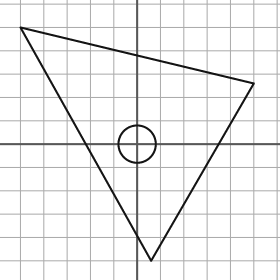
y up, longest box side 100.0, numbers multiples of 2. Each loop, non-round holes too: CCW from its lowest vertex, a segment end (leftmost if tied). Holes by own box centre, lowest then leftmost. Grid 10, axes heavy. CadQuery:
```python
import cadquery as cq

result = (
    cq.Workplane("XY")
    .moveTo(6.0, -50.0)
    .lineTo(50.0, 26.0)
    .lineTo(-50.0, 50.0)
    .close()
    .moveTo(0.0, 0.0)
    .circle(8.0)
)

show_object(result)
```